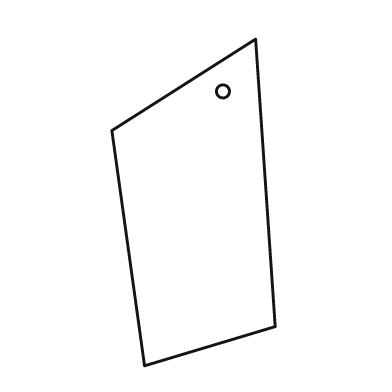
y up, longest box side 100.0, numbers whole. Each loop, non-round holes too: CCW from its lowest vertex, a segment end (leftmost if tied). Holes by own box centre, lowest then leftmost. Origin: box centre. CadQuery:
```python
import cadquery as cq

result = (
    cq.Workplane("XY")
    .moveTo(-15.0, -50.0)
    .lineTo(25.0, -38.0)
    .lineTo(19.0, 50.0)
    .lineTo(-25.0, 22.0)
    .close()
    .moveTo(9.0, 34.0)
    .circle(2.0)
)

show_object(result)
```